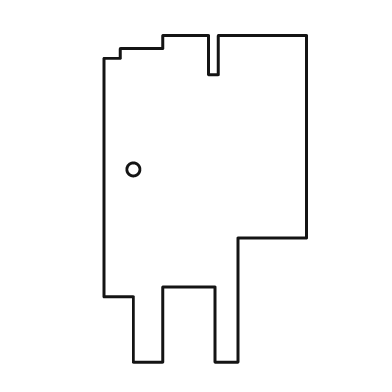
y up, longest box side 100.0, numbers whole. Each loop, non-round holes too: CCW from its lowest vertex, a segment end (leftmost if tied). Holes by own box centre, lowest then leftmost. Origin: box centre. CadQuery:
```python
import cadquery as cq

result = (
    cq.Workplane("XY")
    .moveTo(-22.0, -50.0)
    .lineTo(-13.0, -50.0)
    .lineTo(-13.0, -27.0)
    .lineTo(3.0, -27.0)
    .lineTo(3.0, -50.0)
    .lineTo(10.0, -50.0)
    .lineTo(10.0, -12.0)
    .lineTo(31.0, -12.0)
    .lineTo(31.0, 50.0)
    .lineTo(4.0, 50.0)
    .lineTo(4.0, 38.0)
    .lineTo(1.0, 38.0)
    .lineTo(1.0, 50.0)
    .lineTo(-13.0, 50.0)
    .lineTo(-13.0, 46.0)
    .lineTo(-26.0, 46.0)
    .lineTo(-26.0, 43.0)
    .lineTo(-31.0, 43.0)
    .lineTo(-31.0, -30.0)
    .lineTo(-22.0, -30.0)
    .close()
    .moveTo(-22.0, 9.0)
    .circle(2.0)
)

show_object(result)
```